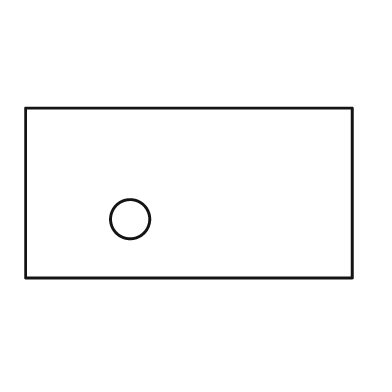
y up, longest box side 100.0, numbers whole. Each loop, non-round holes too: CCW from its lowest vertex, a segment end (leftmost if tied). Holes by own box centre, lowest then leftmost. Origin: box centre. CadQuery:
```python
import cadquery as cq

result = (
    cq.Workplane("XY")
    .moveTo(-50.0, -26.0)
    .lineTo(50.0, -26.0)
    .lineTo(50.0, 26.0)
    .lineTo(-50.0, 26.0)
    .close()
    .moveTo(-18.0, -8.0)
    .circle(6.0)
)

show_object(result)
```